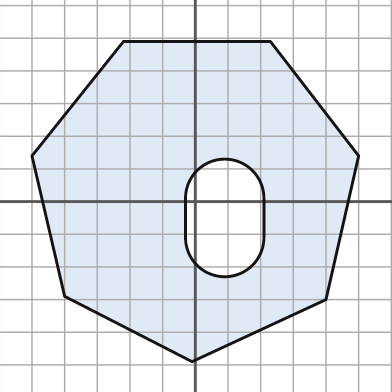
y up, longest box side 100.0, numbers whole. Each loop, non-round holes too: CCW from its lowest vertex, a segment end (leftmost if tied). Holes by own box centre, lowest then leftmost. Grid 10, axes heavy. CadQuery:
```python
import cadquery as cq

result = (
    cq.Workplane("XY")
    .moveTo(-1.0, -49.0)
    .lineTo(40.0, -30.0)
    .lineTo(50.0, 14.0)
    .lineTo(23.0, 49.0)
    .lineTo(-22.0, 49.0)
    .lineTo(-50.0, 14.0)
    .lineTo(-40.0, -29.0)
    .close()
    .moveTo(-3.0, -11.0)
    .threePointArc((9.0, -23.0), (21.0, -11.0))
    .lineTo(21.0, 1.0)
    .threePointArc((9.0, 13.0), (-3.0, 1.0))
    .close()
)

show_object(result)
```